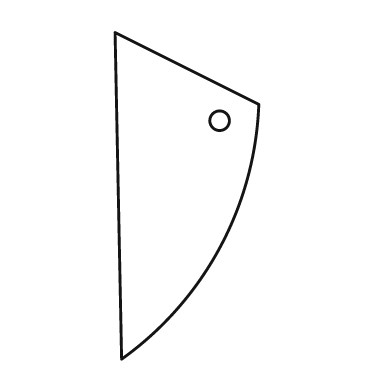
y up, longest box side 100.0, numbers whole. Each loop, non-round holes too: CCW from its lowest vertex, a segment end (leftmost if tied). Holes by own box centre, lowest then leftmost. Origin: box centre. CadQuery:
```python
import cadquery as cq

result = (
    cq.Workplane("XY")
    .moveTo(-20.0, -50.0)
    .threePointArc((10.0, -16.0), (22.0, 28.0))
    .lineTo(-22.0, 50.0)
    .close()
    .moveTo(10.0, 23.0)
    .circle(3.0)
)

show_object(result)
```